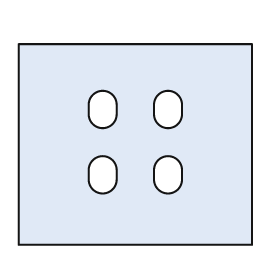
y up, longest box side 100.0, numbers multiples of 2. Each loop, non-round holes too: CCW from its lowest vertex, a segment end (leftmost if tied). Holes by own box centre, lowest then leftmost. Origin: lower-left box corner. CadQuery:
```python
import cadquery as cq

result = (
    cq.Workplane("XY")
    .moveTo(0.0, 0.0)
    .lineTo(100.0, 0.0)
    .lineTo(100.0, 86.0)
    .lineTo(0.0, 86.0)
    .close()
    .moveTo(30.0, 28.0)
    .threePointArc((36.0, 22.0), (42.0, 28.0))
    .lineTo(42.0, 32.0)
    .threePointArc((36.0, 38.0), (30.0, 32.0))
    .close()
    .moveTo(58.0, 28.0)
    .threePointArc((64.0, 22.0), (70.0, 28.0))
    .lineTo(70.0, 32.0)
    .threePointArc((64.0, 38.0), (58.0, 32.0))
    .close()
    .moveTo(30.0, 56.0)
    .threePointArc((36.0, 50.0), (42.0, 56.0))
    .lineTo(42.0, 60.0)
    .threePointArc((36.0, 66.0), (30.0, 60.0))
    .close()
    .moveTo(58.0, 56.0)
    .threePointArc((64.0, 50.0), (70.0, 56.0))
    .lineTo(70.0, 60.0)
    .threePointArc((64.0, 66.0), (58.0, 60.0))
    .close()
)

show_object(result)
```